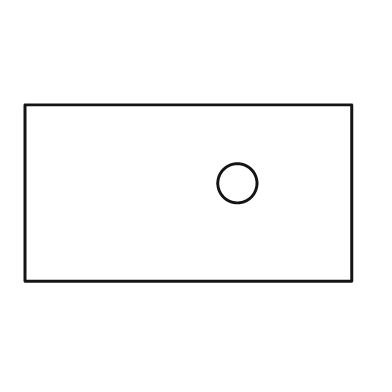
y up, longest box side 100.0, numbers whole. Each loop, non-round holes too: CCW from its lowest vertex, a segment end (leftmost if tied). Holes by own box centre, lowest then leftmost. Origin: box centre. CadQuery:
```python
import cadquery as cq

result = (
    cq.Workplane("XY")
    .moveTo(-50.0, -27.0)
    .lineTo(50.0, -27.0)
    .lineTo(50.0, 27.0)
    .lineTo(-50.0, 27.0)
    .close()
    .moveTo(15.0, 3.0)
    .circle(6.0)
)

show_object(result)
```